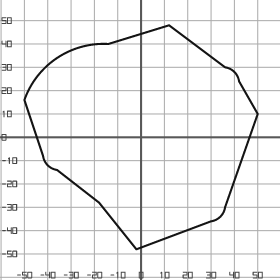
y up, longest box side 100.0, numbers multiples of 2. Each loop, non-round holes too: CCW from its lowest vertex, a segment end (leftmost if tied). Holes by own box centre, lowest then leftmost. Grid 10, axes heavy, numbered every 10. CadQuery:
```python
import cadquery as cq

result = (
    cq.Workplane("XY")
    .moveTo(-2.0, -48.0)
    .lineTo(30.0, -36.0)
    .threePointArc((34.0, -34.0), (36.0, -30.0))
    .lineTo(50.0, 10.0)
    .lineTo(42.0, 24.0)
    .threePointArc((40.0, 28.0), (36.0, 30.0))
    .lineTo(12.0, 48.0)
    .lineTo(-14.0, 40.0)
    .threePointArc((-36.0, 34.0), (-50.0, 16.0))
    .lineTo(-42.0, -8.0)
    .threePointArc((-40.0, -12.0), (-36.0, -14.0))
    .lineTo(-18.0, -28.0)
    .close()
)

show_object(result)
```